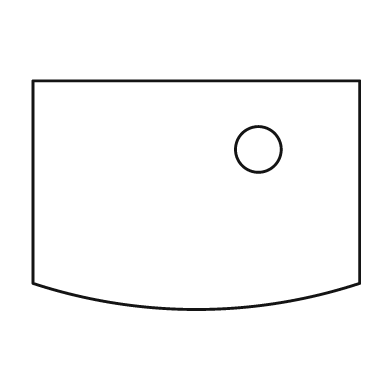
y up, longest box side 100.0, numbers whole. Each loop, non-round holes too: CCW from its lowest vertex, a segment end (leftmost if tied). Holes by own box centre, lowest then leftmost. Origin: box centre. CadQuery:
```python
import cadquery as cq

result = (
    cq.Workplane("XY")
    .moveTo(-50.0, -27.0)
    .threePointArc((0.0, -35.0), (50.0, -27.0))
    .lineTo(50.0, 35.0)
    .lineTo(-50.0, 35.0)
    .close()
    .moveTo(19.0, 14.0)
    .circle(7.0)
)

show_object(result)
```